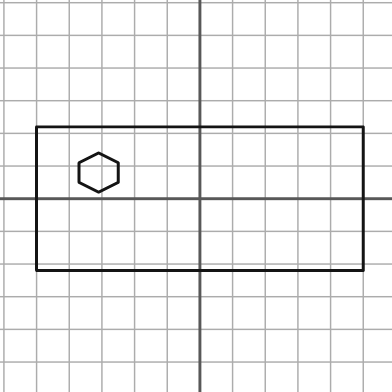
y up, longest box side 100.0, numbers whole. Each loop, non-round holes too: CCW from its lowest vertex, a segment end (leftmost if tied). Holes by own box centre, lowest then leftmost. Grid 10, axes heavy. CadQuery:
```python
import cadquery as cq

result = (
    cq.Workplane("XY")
    .moveTo(-50.0, -22.0)
    .lineTo(50.0, -22.0)
    .lineTo(50.0, 22.0)
    .lineTo(-50.0, 22.0)
    .close()
    .moveTo(-31.0, 2.0)
    .lineTo(-25.0, 5.0)
    .lineTo(-25.0, 11.0)
    .lineTo(-31.0, 14.0)
    .lineTo(-37.0, 11.0)
    .lineTo(-37.0, 5.0)
    .close()
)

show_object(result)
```